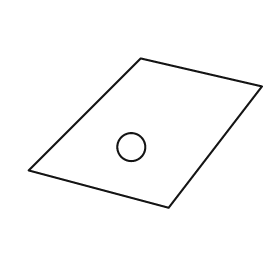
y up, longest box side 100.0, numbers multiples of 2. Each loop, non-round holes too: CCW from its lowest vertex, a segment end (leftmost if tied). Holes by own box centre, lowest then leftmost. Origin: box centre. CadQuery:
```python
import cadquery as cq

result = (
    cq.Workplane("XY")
    .moveTo(10.0, -32.0)
    .lineTo(50.0, 20.0)
    .lineTo(-2.0, 32.0)
    .lineTo(-50.0, -16.0)
    .close()
    .moveTo(-6.0, -6.0)
    .circle(6.0)
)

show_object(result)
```